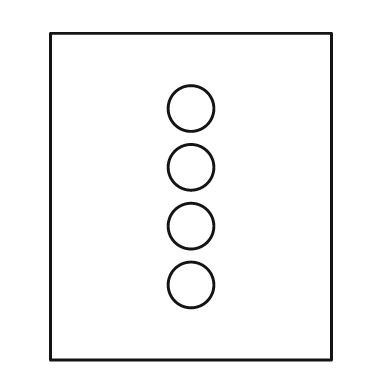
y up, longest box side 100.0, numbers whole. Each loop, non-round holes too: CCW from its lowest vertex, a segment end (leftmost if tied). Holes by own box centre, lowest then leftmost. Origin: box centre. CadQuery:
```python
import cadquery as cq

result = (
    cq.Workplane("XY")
    .moveTo(-43.0, -50.0)
    .lineTo(43.0, -50.0)
    .lineTo(43.0, 50.0)
    .lineTo(-43.0, 50.0)
    .close()
    .moveTo(0.0, -27.0)
    .circle(7.0)
    .moveTo(0.0, -9.0)
    .circle(7.0)
    .moveTo(0.0, 9.0)
    .circle(7.0)
    .moveTo(0.0, 27.0)
    .circle(7.0)
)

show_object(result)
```